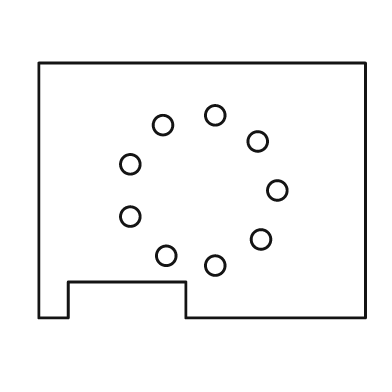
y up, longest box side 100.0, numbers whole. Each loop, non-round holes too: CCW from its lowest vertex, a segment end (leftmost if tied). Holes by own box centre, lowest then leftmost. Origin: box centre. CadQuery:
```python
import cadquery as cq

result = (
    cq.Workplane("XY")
    .moveTo(-50.0, -39.0)
    .lineTo(-41.0, -39.0)
    .lineTo(-41.0, -28.0)
    .lineTo(-5.0, -28.0)
    .lineTo(-5.0, -39.0)
    .lineTo(50.0, -39.0)
    .lineTo(50.0, 39.0)
    .lineTo(-50.0, 39.0)
    .close()
    .moveTo(4.0, -23.0)
    .circle(3.0)
    .moveTo(-11.0, -20.0)
    .circle(3.0)
    .moveTo(18.0, -15.0)
    .circle(3.0)
    .moveTo(-22.0, -8.0)
    .circle(3.0)
    .moveTo(23.0, 0.0)
    .circle(3.0)
    .moveTo(-22.0, 8.0)
    .circle(3.0)
    .moveTo(17.0, 15.0)
    .circle(3.0)
    .moveTo(-12.0, 20.0)
    .circle(3.0)
    .moveTo(4.0, 23.0)
    .circle(3.0)
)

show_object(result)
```